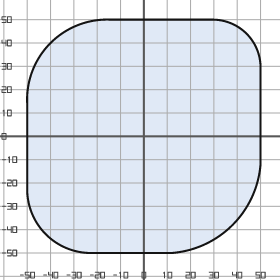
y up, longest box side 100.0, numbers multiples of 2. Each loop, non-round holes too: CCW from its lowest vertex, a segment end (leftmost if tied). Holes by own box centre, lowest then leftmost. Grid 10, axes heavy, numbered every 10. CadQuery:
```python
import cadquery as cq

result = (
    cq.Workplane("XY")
    .moveTo(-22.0, -50.0)
    .lineTo(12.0, -50.0)
    .threePointArc((38.0, -38.0), (50.0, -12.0))
    .lineTo(50.0, 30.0)
    .threePointArc((44.0, 44.0), (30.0, 50.0))
    .lineTo(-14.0, 50.0)
    .threePointArc((-40.0, 40.0), (-50.0, 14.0))
    .lineTo(-50.0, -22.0)
    .threePointArc((-42.0, -42.0), (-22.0, -50.0))
    .close()
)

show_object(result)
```